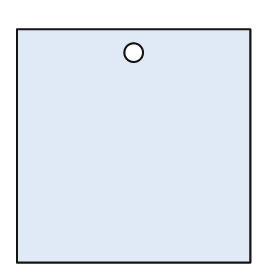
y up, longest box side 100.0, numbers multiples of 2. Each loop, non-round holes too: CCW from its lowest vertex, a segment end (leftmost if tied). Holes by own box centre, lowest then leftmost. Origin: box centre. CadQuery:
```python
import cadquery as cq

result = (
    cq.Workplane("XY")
    .moveTo(-50.0, -50.0)
    .lineTo(50.0, -50.0)
    .lineTo(50.0, 50.0)
    .lineTo(-50.0, 50.0)
    .close()
    .moveTo(0.0, 40.0)
    .circle(4.0)
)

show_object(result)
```